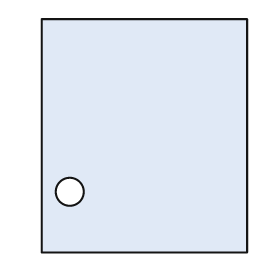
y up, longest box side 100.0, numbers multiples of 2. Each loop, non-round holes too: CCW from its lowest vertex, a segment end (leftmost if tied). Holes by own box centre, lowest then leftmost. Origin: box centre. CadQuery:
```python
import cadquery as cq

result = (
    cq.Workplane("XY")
    .moveTo(-44.0, -50.0)
    .lineTo(44.0, -50.0)
    .lineTo(44.0, 50.0)
    .lineTo(-44.0, 50.0)
    .close()
    .moveTo(-32.0, -24.0)
    .circle(6.0)
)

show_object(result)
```